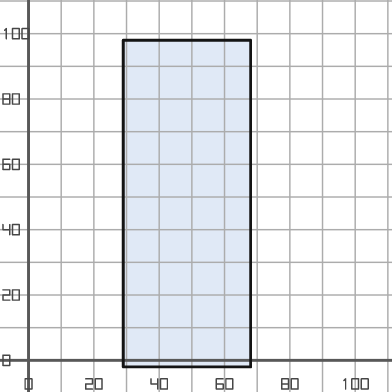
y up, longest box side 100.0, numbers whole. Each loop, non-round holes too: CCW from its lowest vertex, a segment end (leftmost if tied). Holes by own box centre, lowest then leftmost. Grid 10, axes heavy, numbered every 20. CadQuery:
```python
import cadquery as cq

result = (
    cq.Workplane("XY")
    .moveTo(29.0, -2.0)
    .lineTo(68.0, -2.0)
    .lineTo(68.0, 98.0)
    .lineTo(29.0, 98.0)
    .close()
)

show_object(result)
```